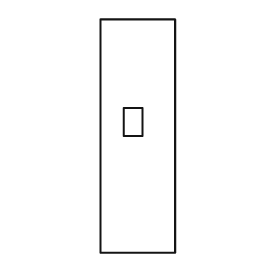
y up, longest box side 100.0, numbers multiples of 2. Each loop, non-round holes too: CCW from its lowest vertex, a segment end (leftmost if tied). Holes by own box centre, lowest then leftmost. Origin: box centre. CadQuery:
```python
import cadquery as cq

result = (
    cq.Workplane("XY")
    .moveTo(-16.0, -50.0)
    .lineTo(16.0, -50.0)
    .lineTo(16.0, 50.0)
    .lineTo(-16.0, 50.0)
    .close()
    .moveTo(-6.0, 0.0)
    .lineTo(2.0, 0.0)
    .lineTo(2.0, 12.0)
    .lineTo(-6.0, 12.0)
    .close()
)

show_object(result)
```